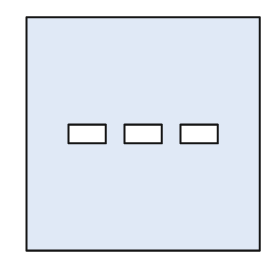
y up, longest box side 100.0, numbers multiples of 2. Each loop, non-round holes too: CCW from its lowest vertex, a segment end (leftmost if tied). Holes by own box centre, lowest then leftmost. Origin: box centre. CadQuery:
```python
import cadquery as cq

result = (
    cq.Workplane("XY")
    .moveTo(-50.0, -50.0)
    .lineTo(50.0, -50.0)
    .lineTo(50.0, 50.0)
    .lineTo(-50.0, 50.0)
    .close()
    .moveTo(-32.0, -4.0)
    .lineTo(-16.0, -4.0)
    .lineTo(-16.0, 4.0)
    .lineTo(-32.0, 4.0)
    .close()
    .moveTo(-8.0, -4.0)
    .lineTo(8.0, -4.0)
    .lineTo(8.0, 4.0)
    .lineTo(-8.0, 4.0)
    .close()
    .moveTo(16.0, -4.0)
    .lineTo(32.0, -4.0)
    .lineTo(32.0, 4.0)
    .lineTo(16.0, 4.0)
    .close()
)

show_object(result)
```